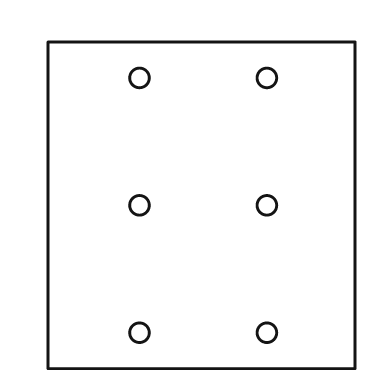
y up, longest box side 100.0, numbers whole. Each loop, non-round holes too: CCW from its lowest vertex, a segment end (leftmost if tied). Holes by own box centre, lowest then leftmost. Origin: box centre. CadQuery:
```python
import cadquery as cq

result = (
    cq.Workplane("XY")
    .moveTo(-47.0, -50.0)
    .lineTo(47.0, -50.0)
    .lineTo(47.0, 50.0)
    .lineTo(-47.0, 50.0)
    .close()
    .moveTo(-19.0, -39.0)
    .circle(3.0)
    .moveTo(20.0, -39.0)
    .circle(3.0)
    .moveTo(-19.0, 0.0)
    .circle(3.0)
    .moveTo(20.0, 0.0)
    .circle(3.0)
    .moveTo(-19.0, 39.0)
    .circle(3.0)
    .moveTo(20.0, 39.0)
    .circle(3.0)
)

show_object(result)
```